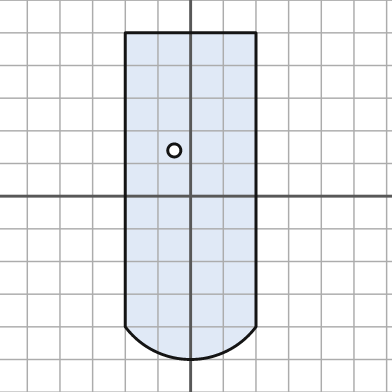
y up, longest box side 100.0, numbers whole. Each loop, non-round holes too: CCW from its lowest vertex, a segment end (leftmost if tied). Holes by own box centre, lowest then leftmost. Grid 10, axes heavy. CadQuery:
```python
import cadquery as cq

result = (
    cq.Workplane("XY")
    .moveTo(-20.0, -40.0)
    .threePointArc((0.0, -50.0), (20.0, -40.0))
    .lineTo(20.0, 50.0)
    .lineTo(-20.0, 50.0)
    .close()
    .moveTo(-5.0, 14.0)
    .circle(2.0)
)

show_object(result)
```